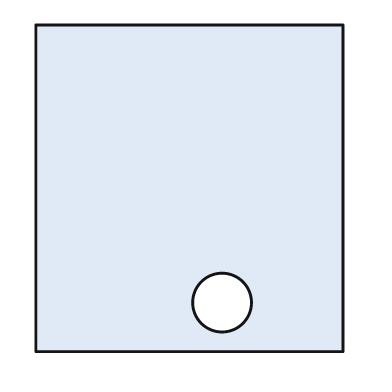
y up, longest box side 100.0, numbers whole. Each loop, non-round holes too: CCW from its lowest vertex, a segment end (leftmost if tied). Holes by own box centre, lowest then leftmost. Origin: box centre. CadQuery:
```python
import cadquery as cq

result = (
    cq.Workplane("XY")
    .moveTo(-47.0, -50.0)
    .lineTo(47.0, -50.0)
    .lineTo(47.0, 50.0)
    .lineTo(-47.0, 50.0)
    .close()
    .moveTo(10.0, -35.0)
    .circle(9.0)
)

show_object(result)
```